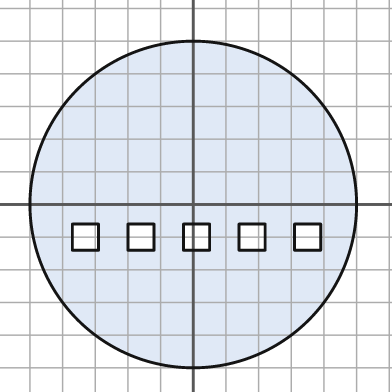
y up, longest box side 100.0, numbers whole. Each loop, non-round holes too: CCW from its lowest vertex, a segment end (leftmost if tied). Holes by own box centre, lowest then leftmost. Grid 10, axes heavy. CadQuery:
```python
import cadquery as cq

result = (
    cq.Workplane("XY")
    .moveTo(0.0, 0.0)
    .circle(50.0)
    .moveTo(-37.0, -14.0)
    .lineTo(-29.0, -14.0)
    .lineTo(-29.0, -6.0)
    .lineTo(-37.0, -6.0)
    .close()
    .moveTo(-20.0, -14.0)
    .lineTo(-12.0, -14.0)
    .lineTo(-12.0, -6.0)
    .lineTo(-20.0, -6.0)
    .close()
    .moveTo(-3.0, -14.0)
    .lineTo(5.0, -14.0)
    .lineTo(5.0, -6.0)
    .lineTo(-3.0, -6.0)
    .close()
    .moveTo(14.0, -14.0)
    .lineTo(22.0, -14.0)
    .lineTo(22.0, -6.0)
    .lineTo(14.0, -6.0)
    .close()
    .moveTo(31.0, -14.0)
    .lineTo(39.0, -14.0)
    .lineTo(39.0, -6.0)
    .lineTo(31.0, -6.0)
    .close()
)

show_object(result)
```